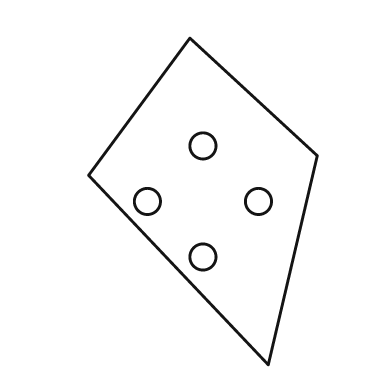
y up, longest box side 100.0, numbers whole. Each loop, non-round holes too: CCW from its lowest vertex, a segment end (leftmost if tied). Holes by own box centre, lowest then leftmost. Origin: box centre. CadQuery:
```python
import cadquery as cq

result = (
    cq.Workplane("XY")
    .moveTo(20.0, -50.0)
    .lineTo(35.0, 14.0)
    .lineTo(-4.0, 50.0)
    .lineTo(-35.0, 8.0)
    .close()
    .moveTo(0.0, -17.0)
    .circle(4.0)
    .moveTo(-17.0, 0.0)
    .circle(4.0)
    .moveTo(17.0, 0.0)
    .circle(4.0)
    .moveTo(0.0, 17.0)
    .circle(4.0)
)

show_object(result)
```